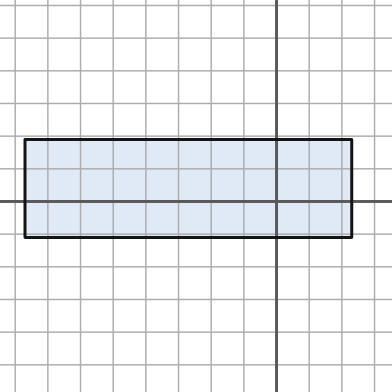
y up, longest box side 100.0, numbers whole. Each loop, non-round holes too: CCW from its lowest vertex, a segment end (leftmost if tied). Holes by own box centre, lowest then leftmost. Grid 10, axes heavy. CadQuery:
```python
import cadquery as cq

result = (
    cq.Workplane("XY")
    .moveTo(-77.0, -11.0)
    .lineTo(23.0, -11.0)
    .lineTo(23.0, 19.0)
    .lineTo(-77.0, 19.0)
    .close()
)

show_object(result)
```